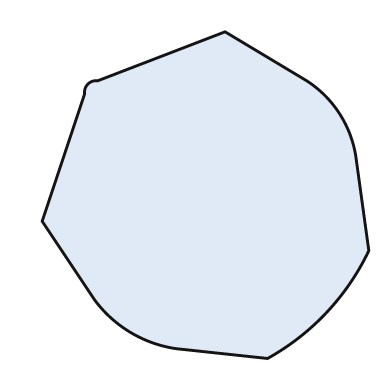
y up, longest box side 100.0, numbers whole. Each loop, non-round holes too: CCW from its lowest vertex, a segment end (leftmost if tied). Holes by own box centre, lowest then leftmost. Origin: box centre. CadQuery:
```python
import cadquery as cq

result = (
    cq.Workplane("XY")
    .moveTo(19.0, -50.0)
    .threePointArc((37.0, -36.0), (50.0, -17.0))
    .lineTo(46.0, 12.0)
    .threePointArc((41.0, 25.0), (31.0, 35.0))
    .lineTo(6.0, 50.0)
    .lineTo(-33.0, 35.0)
    .threePointArc((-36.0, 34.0), (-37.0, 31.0))
    .lineTo(-50.0, -8.0)
    .lineTo(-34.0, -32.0)
    .threePointArc((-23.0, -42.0), (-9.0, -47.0))
    .close()
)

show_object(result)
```